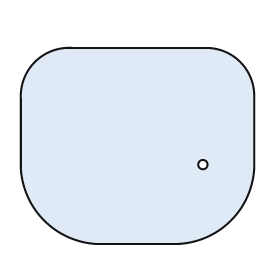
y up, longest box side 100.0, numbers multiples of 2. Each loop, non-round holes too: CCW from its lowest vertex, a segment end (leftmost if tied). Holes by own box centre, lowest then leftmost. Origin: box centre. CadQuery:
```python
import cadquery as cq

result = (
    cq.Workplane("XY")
    .moveTo(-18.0, -42.0)
    .lineTo(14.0, -42.0)
    .threePointArc((40.0, -32.0), (50.0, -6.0))
    .lineTo(50.0, 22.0)
    .threePointArc((44.0, 36.0), (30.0, 42.0))
    .lineTo(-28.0, 42.0)
    .threePointArc((-44.0, 36.0), (-50.0, 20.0))
    .lineTo(-50.0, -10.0)
    .threePointArc((-40.0, -32.0), (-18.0, -42.0))
    .close()
    .moveTo(28.0, -8.0)
    .circle(2.0)
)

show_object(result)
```